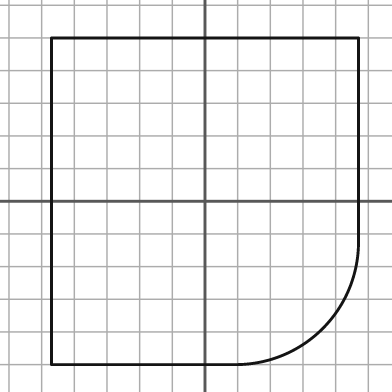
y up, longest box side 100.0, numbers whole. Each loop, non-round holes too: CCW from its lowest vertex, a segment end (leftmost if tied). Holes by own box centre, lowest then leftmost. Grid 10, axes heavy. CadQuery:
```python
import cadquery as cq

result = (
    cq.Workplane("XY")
    .moveTo(-47.0, -50.0)
    .lineTo(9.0, -50.0)
    .threePointArc((36.0, -39.0), (47.0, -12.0))
    .lineTo(47.0, 50.0)
    .lineTo(-47.0, 50.0)
    .close()
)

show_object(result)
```